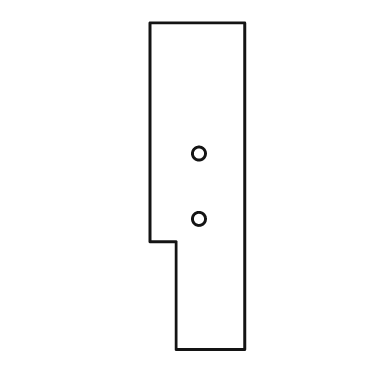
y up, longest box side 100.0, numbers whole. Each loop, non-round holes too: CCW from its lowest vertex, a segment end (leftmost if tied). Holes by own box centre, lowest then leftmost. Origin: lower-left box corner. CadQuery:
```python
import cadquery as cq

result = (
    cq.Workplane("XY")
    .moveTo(8.0, 0.0)
    .lineTo(29.0, 0.0)
    .lineTo(29.0, 100.0)
    .lineTo(0.0, 100.0)
    .lineTo(0.0, 33.0)
    .lineTo(8.0, 33.0)
    .close()
    .moveTo(15.0, 40.0)
    .circle(2.0)
    .moveTo(15.0, 60.0)
    .circle(2.0)
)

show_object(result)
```